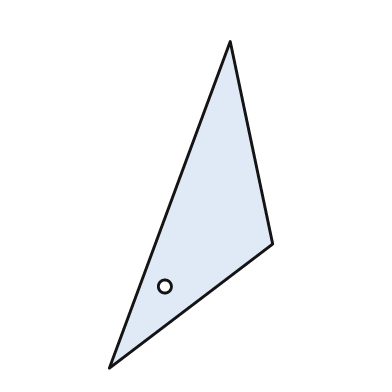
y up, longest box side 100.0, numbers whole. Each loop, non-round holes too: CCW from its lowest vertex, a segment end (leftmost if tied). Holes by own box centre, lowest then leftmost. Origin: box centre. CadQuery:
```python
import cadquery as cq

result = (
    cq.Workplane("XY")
    .moveTo(-25.0, -50.0)
    .lineTo(25.0, -12.0)
    .lineTo(12.0, 50.0)
    .close()
    .moveTo(-8.0, -25.0)
    .circle(2.0)
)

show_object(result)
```